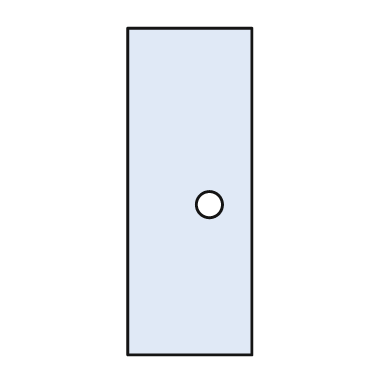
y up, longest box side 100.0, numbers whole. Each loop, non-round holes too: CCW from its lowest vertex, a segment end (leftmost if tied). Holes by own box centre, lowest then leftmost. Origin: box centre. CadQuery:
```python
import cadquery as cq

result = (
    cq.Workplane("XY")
    .moveTo(-19.0, -50.0)
    .lineTo(19.0, -50.0)
    .lineTo(19.0, 50.0)
    .lineTo(-19.0, 50.0)
    .close()
    .moveTo(6.0, -4.0)
    .circle(4.0)
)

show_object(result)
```